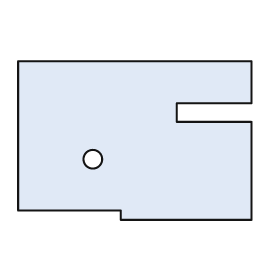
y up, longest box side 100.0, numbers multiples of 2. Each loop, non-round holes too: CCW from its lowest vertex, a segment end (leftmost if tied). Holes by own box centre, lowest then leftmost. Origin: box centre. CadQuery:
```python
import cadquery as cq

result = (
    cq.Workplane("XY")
    .moveTo(-6.0, -34.0)
    .lineTo(50.0, -34.0)
    .lineTo(50.0, 8.0)
    .lineTo(18.0, 8.0)
    .lineTo(18.0, 16.0)
    .lineTo(50.0, 16.0)
    .lineTo(50.0, 34.0)
    .lineTo(-50.0, 34.0)
    .lineTo(-50.0, -30.0)
    .lineTo(-6.0, -30.0)
    .close()
    .moveTo(-18.0, -8.0)
    .circle(4.0)
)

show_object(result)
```